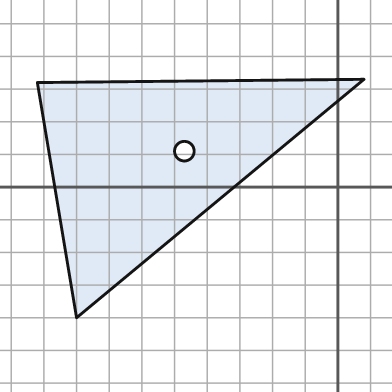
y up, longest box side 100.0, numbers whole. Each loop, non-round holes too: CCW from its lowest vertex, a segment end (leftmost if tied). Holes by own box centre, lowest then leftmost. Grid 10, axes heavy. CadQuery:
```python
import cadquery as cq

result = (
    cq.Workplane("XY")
    .moveTo(-80.0, -40.0)
    .lineTo(8.0, 33.0)
    .lineTo(-92.0, 32.0)
    .close()
    .moveTo(-47.0, 11.0)
    .circle(3.0)
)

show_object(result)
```